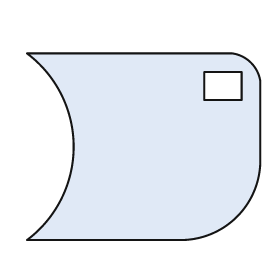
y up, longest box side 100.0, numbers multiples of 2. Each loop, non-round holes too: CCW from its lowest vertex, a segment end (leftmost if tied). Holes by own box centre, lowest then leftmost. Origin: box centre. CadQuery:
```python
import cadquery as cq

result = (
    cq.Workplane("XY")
    .moveTo(-50.0, -40.0)
    .lineTo(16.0, -40.0)
    .threePointArc((40.0, -30.0), (50.0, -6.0))
    .lineTo(50.0, 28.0)
    .threePointArc((46.0, 36.0), (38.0, 40.0))
    .lineTo(-50.0, 40.0)
    .threePointArc((-30.0, 0.0), (-50.0, -40.0))
    .close()
    .moveTo(26.0, 20.0)
    .lineTo(42.0, 20.0)
    .lineTo(42.0, 32.0)
    .lineTo(26.0, 32.0)
    .close()
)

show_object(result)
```